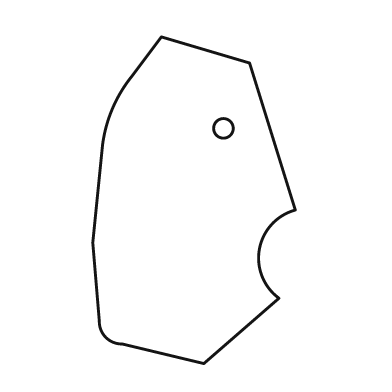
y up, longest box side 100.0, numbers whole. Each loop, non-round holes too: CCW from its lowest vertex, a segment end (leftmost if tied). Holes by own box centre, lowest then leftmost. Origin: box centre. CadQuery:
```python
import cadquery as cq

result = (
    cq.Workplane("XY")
    .moveTo(3.0, -50.0)
    .lineTo(26.0, -30.0)
    .threePointArc((20.0, -15.0), (31.0, -3.0))
    .lineTo(17.0, 42.0)
    .lineTo(-10.0, 50.0)
    .lineTo(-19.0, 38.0)
    .threePointArc((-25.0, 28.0), (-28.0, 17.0))
    .lineTo(-31.0, -13.0)
    .lineTo(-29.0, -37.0)
    .threePointArc((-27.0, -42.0), (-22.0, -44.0))
    .close()
    .moveTo(9.0, 22.0)
    .circle(3.0)
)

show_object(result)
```